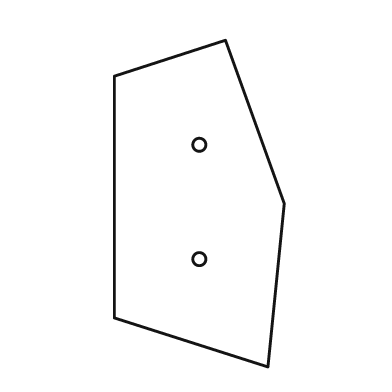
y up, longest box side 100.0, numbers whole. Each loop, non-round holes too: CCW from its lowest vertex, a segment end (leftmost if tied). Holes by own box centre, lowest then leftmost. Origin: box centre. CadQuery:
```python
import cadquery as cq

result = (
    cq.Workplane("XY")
    .moveTo(21.0, -50.0)
    .lineTo(26.0, 0.0)
    .lineTo(8.0, 50.0)
    .lineTo(-26.0, 39.0)
    .lineTo(-26.0, -35.0)
    .close()
    .moveTo(0.0, -17.0)
    .circle(2.0)
    .moveTo(0.0, 18.0)
    .circle(2.0)
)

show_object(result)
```